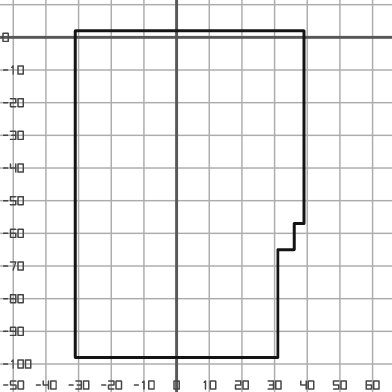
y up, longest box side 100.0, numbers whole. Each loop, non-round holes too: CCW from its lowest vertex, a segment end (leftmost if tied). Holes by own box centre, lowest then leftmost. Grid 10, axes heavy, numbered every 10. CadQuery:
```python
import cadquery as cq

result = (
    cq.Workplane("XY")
    .moveTo(-31.0, -98.0)
    .lineTo(31.0, -98.0)
    .lineTo(31.0, -65.0)
    .lineTo(36.0, -65.0)
    .lineTo(36.0, -57.0)
    .lineTo(39.0, -57.0)
    .lineTo(39.0, 2.0)
    .lineTo(-31.0, 2.0)
    .close()
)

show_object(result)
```